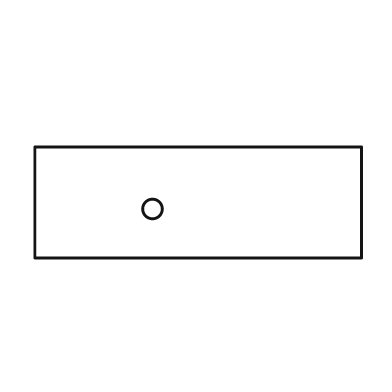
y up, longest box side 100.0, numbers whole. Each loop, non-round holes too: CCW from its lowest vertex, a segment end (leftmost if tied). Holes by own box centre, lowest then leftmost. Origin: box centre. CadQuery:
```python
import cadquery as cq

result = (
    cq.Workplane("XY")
    .moveTo(-50.0, -17.0)
    .lineTo(50.0, -17.0)
    .lineTo(50.0, 17.0)
    .lineTo(-50.0, 17.0)
    .close()
    .moveTo(-14.0, -2.0)
    .circle(3.0)
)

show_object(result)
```